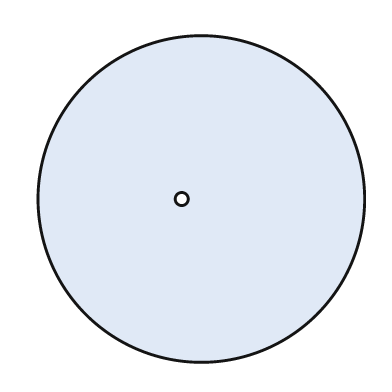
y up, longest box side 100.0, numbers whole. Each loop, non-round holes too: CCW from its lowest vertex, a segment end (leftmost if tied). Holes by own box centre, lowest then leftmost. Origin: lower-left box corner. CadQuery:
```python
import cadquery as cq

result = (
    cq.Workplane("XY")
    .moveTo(50.0, 50.0)
    .circle(50.0)
    .moveTo(44.0, 50.0)
    .circle(2.0)
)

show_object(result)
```